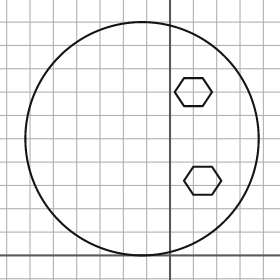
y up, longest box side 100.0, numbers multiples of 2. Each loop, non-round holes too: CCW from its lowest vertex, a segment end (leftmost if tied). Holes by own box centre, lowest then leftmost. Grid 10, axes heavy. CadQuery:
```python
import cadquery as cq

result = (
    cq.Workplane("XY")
    .moveTo(-12.0, 50.0)
    .circle(50.0)
    .moveTo(10.0, 26.0)
    .lineTo(18.0, 26.0)
    .lineTo(22.0, 32.0)
    .lineTo(18.0, 38.0)
    .lineTo(10.0, 38.0)
    .lineTo(6.0, 32.0)
    .close()
    .moveTo(6.0, 64.0)
    .lineTo(14.0, 64.0)
    .lineTo(18.0, 70.0)
    .lineTo(14.0, 76.0)
    .lineTo(6.0, 76.0)
    .lineTo(2.0, 70.0)
    .close()
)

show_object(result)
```